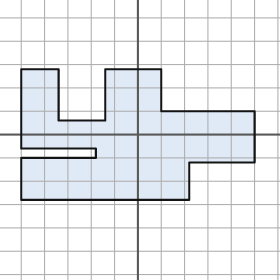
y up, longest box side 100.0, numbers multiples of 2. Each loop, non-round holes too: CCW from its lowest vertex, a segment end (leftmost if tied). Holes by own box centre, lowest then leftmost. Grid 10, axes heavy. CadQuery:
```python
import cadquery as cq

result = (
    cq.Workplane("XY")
    .moveTo(-50.0, -28.0)
    .lineTo(22.0, -28.0)
    .lineTo(22.0, -12.0)
    .lineTo(50.0, -12.0)
    .lineTo(50.0, 10.0)
    .lineTo(10.0, 10.0)
    .lineTo(10.0, 28.0)
    .lineTo(-14.0, 28.0)
    .lineTo(-14.0, 6.0)
    .lineTo(-34.0, 6.0)
    .lineTo(-34.0, 28.0)
    .lineTo(-50.0, 28.0)
    .lineTo(-50.0, -6.0)
    .lineTo(-18.0, -6.0)
    .lineTo(-18.0, -10.0)
    .lineTo(-50.0, -10.0)
    .close()
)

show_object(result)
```